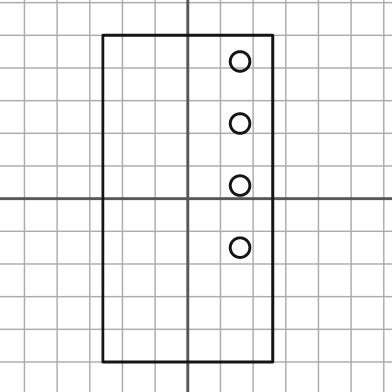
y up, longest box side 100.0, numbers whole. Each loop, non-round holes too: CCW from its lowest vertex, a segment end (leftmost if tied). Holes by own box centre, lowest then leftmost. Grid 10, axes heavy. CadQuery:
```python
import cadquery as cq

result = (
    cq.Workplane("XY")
    .moveTo(-26.0, -50.0)
    .lineTo(26.0, -50.0)
    .lineTo(26.0, 50.0)
    .lineTo(-26.0, 50.0)
    .close()
    .moveTo(16.0, -15.0)
    .circle(3.0)
    .moveTo(16.0, 4.0)
    .circle(3.0)
    .moveTo(16.0, 23.0)
    .circle(3.0)
    .moveTo(16.0, 42.0)
    .circle(3.0)
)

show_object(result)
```